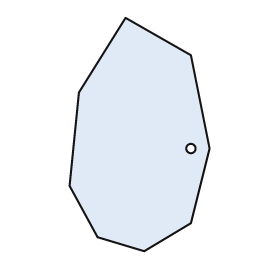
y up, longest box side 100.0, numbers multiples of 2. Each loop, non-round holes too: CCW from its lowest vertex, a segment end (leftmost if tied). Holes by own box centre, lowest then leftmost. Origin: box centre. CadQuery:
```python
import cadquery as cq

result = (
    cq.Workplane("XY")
    .moveTo(2.0, -50.0)
    .lineTo(22.0, -38.0)
    .lineTo(30.0, -6.0)
    .lineTo(22.0, 34.0)
    .lineTo(-6.0, 50.0)
    .lineTo(-26.0, 18.0)
    .lineTo(-30.0, -22.0)
    .lineTo(-18.0, -44.0)
    .close()
    .moveTo(22.0, -6.0)
    .circle(2.0)
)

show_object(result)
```